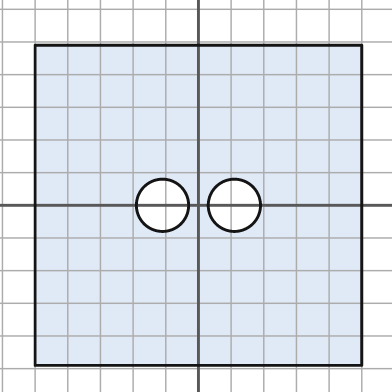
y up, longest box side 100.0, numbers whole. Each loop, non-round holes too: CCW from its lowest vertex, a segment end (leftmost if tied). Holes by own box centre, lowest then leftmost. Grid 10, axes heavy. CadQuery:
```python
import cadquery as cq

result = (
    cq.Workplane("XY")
    .moveTo(-50.0, -49.0)
    .lineTo(50.0, -49.0)
    .lineTo(50.0, 49.0)
    .lineTo(-50.0, 49.0)
    .close()
    .moveTo(-11.0, 0.0)
    .circle(8.0)
    .moveTo(11.0, 0.0)
    .circle(8.0)
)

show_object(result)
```